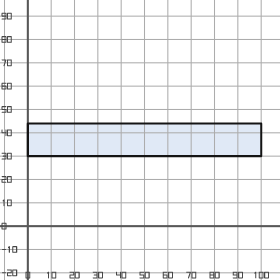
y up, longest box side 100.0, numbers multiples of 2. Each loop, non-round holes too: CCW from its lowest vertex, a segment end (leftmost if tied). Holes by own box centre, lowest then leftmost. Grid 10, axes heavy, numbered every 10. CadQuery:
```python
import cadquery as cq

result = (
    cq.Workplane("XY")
    .moveTo(0.0, 30.0)
    .lineTo(100.0, 30.0)
    .lineTo(100.0, 44.0)
    .lineTo(0.0, 44.0)
    .close()
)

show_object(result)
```